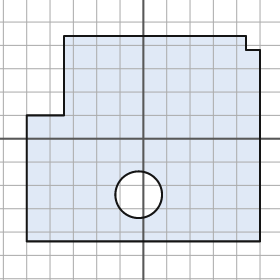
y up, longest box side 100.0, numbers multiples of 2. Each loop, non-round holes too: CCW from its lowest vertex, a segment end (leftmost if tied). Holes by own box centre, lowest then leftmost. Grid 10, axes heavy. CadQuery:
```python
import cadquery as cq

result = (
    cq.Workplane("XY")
    .moveTo(-50.0, -44.0)
    .lineTo(50.0, -44.0)
    .lineTo(50.0, 38.0)
    .lineTo(44.0, 38.0)
    .lineTo(44.0, 44.0)
    .lineTo(-34.0, 44.0)
    .lineTo(-34.0, 10.0)
    .lineTo(-50.0, 10.0)
    .close()
    .moveTo(-2.0, -24.0)
    .circle(10.0)
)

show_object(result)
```